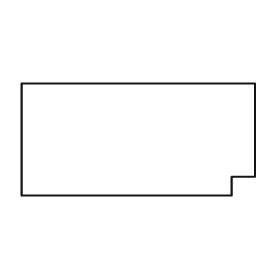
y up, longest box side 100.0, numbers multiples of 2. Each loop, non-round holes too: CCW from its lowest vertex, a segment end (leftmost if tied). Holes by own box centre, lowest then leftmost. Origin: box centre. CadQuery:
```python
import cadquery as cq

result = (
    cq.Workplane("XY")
    .moveTo(-50.0, -24.0)
    .lineTo(40.0, -24.0)
    .lineTo(40.0, -16.0)
    .lineTo(50.0, -16.0)
    .lineTo(50.0, 24.0)
    .lineTo(-50.0, 24.0)
    .close()
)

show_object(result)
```